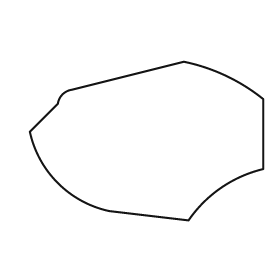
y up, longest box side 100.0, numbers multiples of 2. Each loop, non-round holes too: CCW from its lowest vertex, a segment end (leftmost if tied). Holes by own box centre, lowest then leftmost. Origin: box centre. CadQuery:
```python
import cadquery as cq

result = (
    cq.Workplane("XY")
    .moveTo(18.0, -34.0)
    .threePointArc((32.0, -20.0), (50.0, -12.0))
    .lineTo(50.0, 18.0)
    .threePointArc((34.0, 28.0), (16.0, 34.0))
    .lineTo(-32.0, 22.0)
    .threePointArc((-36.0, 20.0), (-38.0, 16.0))
    .lineTo(-50.0, 4.0)
    .threePointArc((-38.0, -18.0), (-16.0, -30.0))
    .close()
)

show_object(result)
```